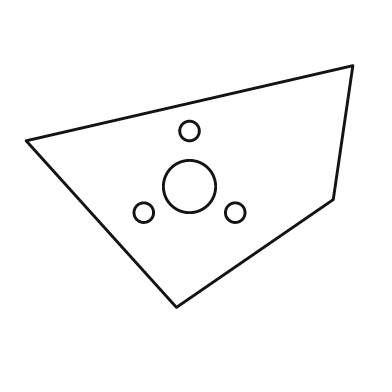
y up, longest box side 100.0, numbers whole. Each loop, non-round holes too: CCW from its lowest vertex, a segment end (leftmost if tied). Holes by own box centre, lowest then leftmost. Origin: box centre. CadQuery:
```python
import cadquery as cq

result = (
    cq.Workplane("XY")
    .moveTo(-4.0, -37.0)
    .lineTo(44.0, -4.0)
    .lineTo(50.0, 37.0)
    .lineTo(-50.0, 14.0)
    .close()
    .moveTo(-14.0, -8.0)
    .circle(3.0)
    .moveTo(14.0, -8.0)
    .circle(3.0)
    .moveTo(0.0, 0.0)
    .circle(8.0)
    .moveTo(0.0, 17.0)
    .circle(3.0)
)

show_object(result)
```